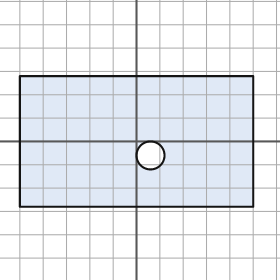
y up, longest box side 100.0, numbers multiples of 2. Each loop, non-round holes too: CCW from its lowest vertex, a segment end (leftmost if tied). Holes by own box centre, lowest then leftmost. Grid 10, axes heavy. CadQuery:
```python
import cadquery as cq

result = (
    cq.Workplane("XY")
    .moveTo(-50.0, -28.0)
    .lineTo(50.0, -28.0)
    .lineTo(50.0, 28.0)
    .lineTo(-50.0, 28.0)
    .close()
    .moveTo(6.0, -6.0)
    .circle(6.0)
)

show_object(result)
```